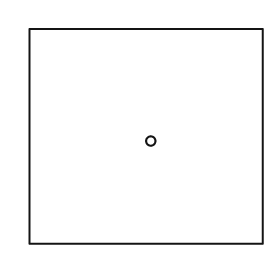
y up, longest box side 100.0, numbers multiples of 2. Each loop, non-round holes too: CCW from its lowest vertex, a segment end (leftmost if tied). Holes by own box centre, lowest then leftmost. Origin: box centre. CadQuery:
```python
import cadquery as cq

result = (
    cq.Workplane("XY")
    .moveTo(-50.0, -46.0)
    .lineTo(50.0, -46.0)
    .lineTo(50.0, 46.0)
    .lineTo(-50.0, 46.0)
    .close()
    .moveTo(2.0, -2.0)
    .circle(2.0)
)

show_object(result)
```